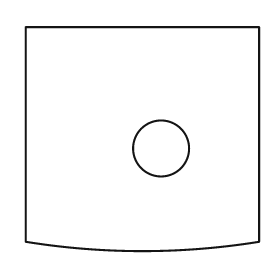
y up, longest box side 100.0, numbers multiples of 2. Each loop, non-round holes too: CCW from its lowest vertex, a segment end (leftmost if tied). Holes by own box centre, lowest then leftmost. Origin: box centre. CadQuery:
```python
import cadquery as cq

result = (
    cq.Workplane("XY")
    .moveTo(-50.0, -44.0)
    .threePointArc((0.0, -48.0), (50.0, -44.0))
    .lineTo(50.0, 48.0)
    .lineTo(-50.0, 48.0)
    .close()
    .moveTo(8.0, -4.0)
    .circle(12.0)
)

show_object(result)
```